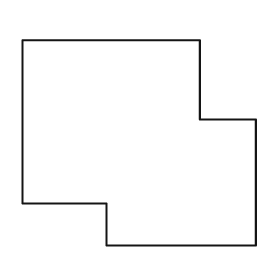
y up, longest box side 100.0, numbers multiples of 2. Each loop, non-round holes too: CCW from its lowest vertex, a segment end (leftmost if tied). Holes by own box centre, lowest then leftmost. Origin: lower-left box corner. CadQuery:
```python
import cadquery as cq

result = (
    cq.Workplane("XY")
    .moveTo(36.0, 0.0)
    .lineTo(100.0, 0.0)
    .lineTo(100.0, 54.0)
    .lineTo(76.0, 54.0)
    .lineTo(76.0, 88.0)
    .lineTo(0.0, 88.0)
    .lineTo(0.0, 18.0)
    .lineTo(36.0, 18.0)
    .close()
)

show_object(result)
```